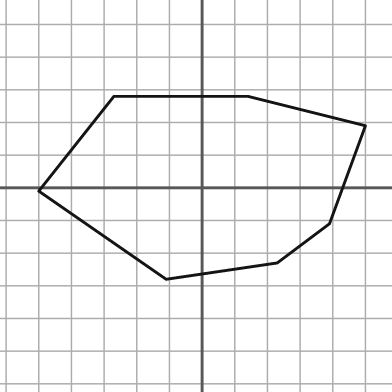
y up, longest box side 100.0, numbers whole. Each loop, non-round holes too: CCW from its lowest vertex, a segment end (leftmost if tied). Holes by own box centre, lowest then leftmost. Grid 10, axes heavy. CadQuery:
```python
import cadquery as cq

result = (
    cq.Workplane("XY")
    .moveTo(-11.0, -28.0)
    .lineTo(23.0, -23.0)
    .lineTo(39.0, -11.0)
    .lineTo(50.0, 19.0)
    .lineTo(14.0, 28.0)
    .lineTo(-27.0, 28.0)
    .lineTo(-50.0, -1.0)
    .close()
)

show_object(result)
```